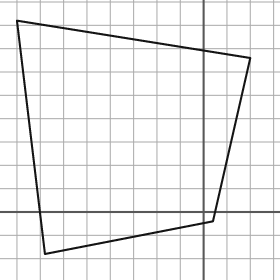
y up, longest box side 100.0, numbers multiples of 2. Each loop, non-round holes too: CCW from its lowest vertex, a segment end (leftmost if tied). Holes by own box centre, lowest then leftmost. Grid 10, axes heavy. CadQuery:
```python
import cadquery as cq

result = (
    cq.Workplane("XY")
    .moveTo(-68.0, -18.0)
    .lineTo(4.0, -4.0)
    .lineTo(20.0, 66.0)
    .lineTo(-80.0, 82.0)
    .close()
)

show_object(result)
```